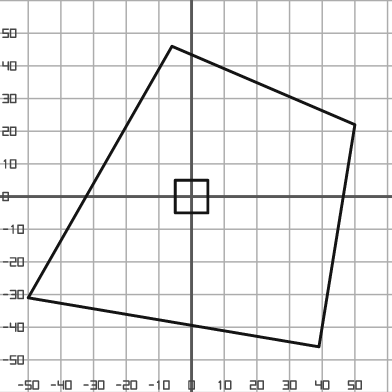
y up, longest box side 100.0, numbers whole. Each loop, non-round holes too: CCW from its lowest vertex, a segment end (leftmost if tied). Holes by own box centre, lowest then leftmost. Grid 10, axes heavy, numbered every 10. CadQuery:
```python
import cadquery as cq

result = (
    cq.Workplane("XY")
    .moveTo(39.0, -46.0)
    .lineTo(50.0, 22.0)
    .lineTo(-6.0, 46.0)
    .lineTo(-50.0, -31.0)
    .close()
    .moveTo(-5.0, -5.0)
    .lineTo(5.0, -5.0)
    .lineTo(5.0, 5.0)
    .lineTo(-5.0, 5.0)
    .close()
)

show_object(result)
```